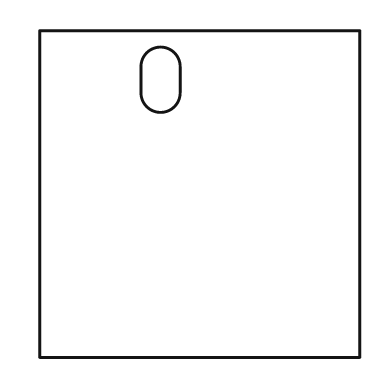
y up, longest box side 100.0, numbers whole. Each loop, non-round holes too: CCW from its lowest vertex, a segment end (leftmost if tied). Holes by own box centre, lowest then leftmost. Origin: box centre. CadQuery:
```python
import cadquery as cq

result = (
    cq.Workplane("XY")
    .moveTo(-49.0, -50.0)
    .lineTo(49.0, -50.0)
    .lineTo(49.0, 50.0)
    .lineTo(-49.0, 50.0)
    .close()
    .moveTo(-18.0, 31.0)
    .threePointArc((-12.0, 25.0), (-6.0, 31.0))
    .lineTo(-6.0, 39.0)
    .threePointArc((-12.0, 45.0), (-18.0, 39.0))
    .close()
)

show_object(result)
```